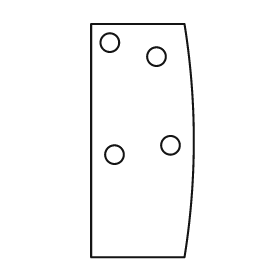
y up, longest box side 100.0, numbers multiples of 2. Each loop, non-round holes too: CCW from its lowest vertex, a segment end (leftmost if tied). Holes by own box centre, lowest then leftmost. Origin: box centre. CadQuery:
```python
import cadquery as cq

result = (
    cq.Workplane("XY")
    .moveTo(-22.0, -50.0)
    .lineTo(18.0, -50.0)
    .threePointArc((22.0, 0.0), (18.0, 50.0))
    .lineTo(-22.0, 50.0)
    .close()
    .moveTo(-12.0, -6.0)
    .circle(4.0)
    .moveTo(12.0, -2.0)
    .circle(4.0)
    .moveTo(6.0, 36.0)
    .circle(4.0)
    .moveTo(-14.0, 42.0)
    .circle(4.0)
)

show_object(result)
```